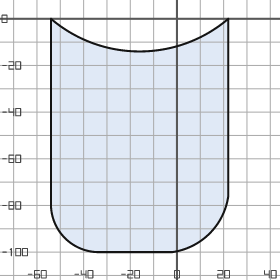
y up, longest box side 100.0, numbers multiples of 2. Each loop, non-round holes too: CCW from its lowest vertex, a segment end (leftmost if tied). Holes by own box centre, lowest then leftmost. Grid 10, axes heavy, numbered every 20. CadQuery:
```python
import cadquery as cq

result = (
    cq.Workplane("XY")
    .moveTo(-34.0, -100.0)
    .lineTo(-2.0, -100.0)
    .threePointArc((14.0, -92.0), (22.0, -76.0))
    .lineTo(22.0, 0.0)
    .threePointArc((-16.0, -14.0), (-54.0, 0.0))
    .lineTo(-54.0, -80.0)
    .threePointArc((-48.0, -94.0), (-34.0, -100.0))
    .close()
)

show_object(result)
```